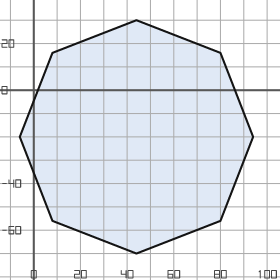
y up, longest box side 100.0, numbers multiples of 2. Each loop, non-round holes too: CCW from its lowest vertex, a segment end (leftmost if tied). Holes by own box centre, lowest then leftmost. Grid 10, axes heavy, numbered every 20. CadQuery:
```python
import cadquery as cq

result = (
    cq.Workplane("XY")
    .moveTo(44.0, -70.0)
    .lineTo(80.0, -56.0)
    .lineTo(94.0, -20.0)
    .lineTo(80.0, 16.0)
    .lineTo(44.0, 30.0)
    .lineTo(8.0, 16.0)
    .lineTo(-6.0, -20.0)
    .lineTo(8.0, -56.0)
    .close()
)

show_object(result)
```